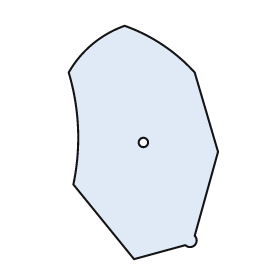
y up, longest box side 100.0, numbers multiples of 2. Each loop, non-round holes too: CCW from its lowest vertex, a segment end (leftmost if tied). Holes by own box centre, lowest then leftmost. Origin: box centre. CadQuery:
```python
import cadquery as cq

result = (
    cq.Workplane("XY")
    .moveTo(-4.0, -50.0)
    .lineTo(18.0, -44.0)
    .threePointArc((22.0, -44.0), (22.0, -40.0))
    .lineTo(32.0, -4.0)
    .lineTo(22.0, 30.0)
    .threePointArc((8.0, 42.0), (-8.0, 50.0))
    .threePointArc((-22.0, 42.0), (-32.0, 30.0))
    .threePointArc((-28.0, 6.0), (-30.0, -18.0))
    .close()
    .moveTo(0.0, 0.0)
    .circle(2.0)
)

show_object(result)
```